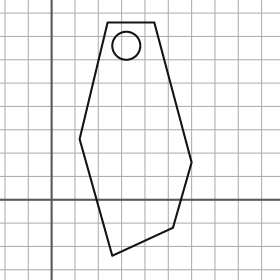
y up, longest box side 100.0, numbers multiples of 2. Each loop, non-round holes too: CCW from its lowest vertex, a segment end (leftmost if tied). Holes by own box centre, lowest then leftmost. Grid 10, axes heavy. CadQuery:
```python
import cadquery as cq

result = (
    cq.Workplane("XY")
    .moveTo(26.0, -24.0)
    .lineTo(52.0, -12.0)
    .lineTo(60.0, 16.0)
    .lineTo(44.0, 76.0)
    .lineTo(24.0, 76.0)
    .lineTo(12.0, 26.0)
    .close()
    .moveTo(32.0, 66.0)
    .circle(6.0)
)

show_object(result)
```